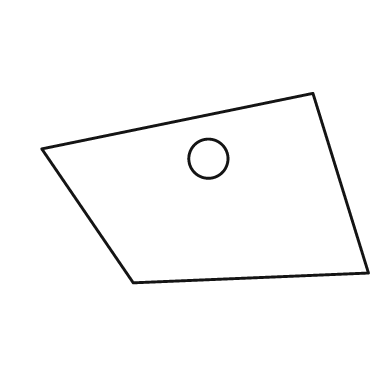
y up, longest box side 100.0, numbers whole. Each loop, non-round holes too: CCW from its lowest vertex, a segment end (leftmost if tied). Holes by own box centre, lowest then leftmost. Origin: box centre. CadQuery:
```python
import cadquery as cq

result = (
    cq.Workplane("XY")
    .moveTo(-22.0, -29.0)
    .lineTo(50.0, -26.0)
    .lineTo(33.0, 29.0)
    .lineTo(-50.0, 12.0)
    .close()
    .moveTo(1.0, 9.0)
    .circle(6.0)
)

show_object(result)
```